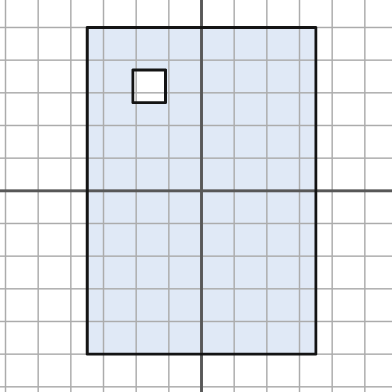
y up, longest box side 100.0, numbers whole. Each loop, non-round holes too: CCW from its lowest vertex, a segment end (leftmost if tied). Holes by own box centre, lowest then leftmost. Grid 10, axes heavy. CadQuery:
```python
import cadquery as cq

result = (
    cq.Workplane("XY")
    .moveTo(-35.0, -50.0)
    .lineTo(35.0, -50.0)
    .lineTo(35.0, 50.0)
    .lineTo(-35.0, 50.0)
    .close()
    .moveTo(-21.0, 27.0)
    .lineTo(-11.0, 27.0)
    .lineTo(-11.0, 37.0)
    .lineTo(-21.0, 37.0)
    .close()
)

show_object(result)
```